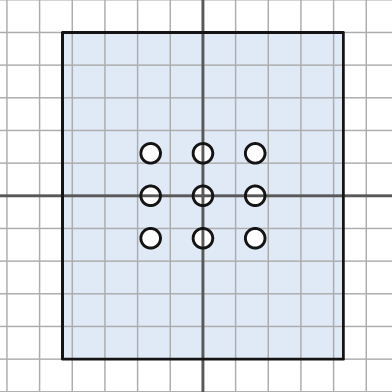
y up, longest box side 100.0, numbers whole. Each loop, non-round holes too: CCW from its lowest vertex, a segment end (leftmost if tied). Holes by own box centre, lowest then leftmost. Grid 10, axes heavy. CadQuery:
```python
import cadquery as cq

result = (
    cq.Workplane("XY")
    .moveTo(-43.0, -50.0)
    .lineTo(43.0, -50.0)
    .lineTo(43.0, 50.0)
    .lineTo(-43.0, 50.0)
    .close()
    .moveTo(-16.0, -13.0)
    .circle(3.0)
    .moveTo(0.0, -13.0)
    .circle(3.0)
    .moveTo(16.0, -13.0)
    .circle(3.0)
    .moveTo(-16.0, 0.0)
    .circle(3.0)
    .moveTo(0.0, 0.0)
    .circle(3.0)
    .moveTo(16.0, 0.0)
    .circle(3.0)
    .moveTo(-16.0, 13.0)
    .circle(3.0)
    .moveTo(0.0, 13.0)
    .circle(3.0)
    .moveTo(16.0, 13.0)
    .circle(3.0)
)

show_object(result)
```